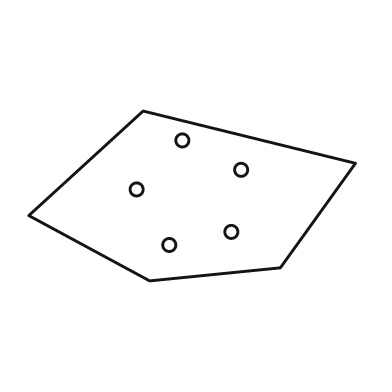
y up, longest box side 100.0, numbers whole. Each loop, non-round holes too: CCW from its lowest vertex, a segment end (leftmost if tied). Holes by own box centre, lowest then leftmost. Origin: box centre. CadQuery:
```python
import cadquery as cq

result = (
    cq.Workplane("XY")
    .moveTo(-13.0, -26.0)
    .lineTo(27.0, -22.0)
    .lineTo(50.0, 10.0)
    .lineTo(-15.0, 26.0)
    .lineTo(-50.0, -6.0)
    .close()
    .moveTo(-7.0, -15.0)
    .circle(2.0)
    .moveTo(12.0, -11.0)
    .circle(2.0)
    .moveTo(-17.0, 2.0)
    .circle(2.0)
    .moveTo(15.0, 8.0)
    .circle(2.0)
    .moveTo(-3.0, 17.0)
    .circle(2.0)
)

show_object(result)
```